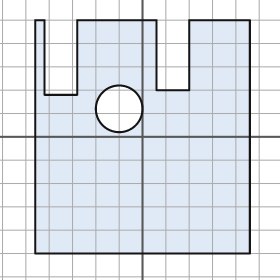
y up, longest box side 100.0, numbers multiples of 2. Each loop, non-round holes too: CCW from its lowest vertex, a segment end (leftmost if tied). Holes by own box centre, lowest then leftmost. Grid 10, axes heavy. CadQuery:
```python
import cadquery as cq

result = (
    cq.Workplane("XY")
    .moveTo(-46.0, -50.0)
    .lineTo(46.0, -50.0)
    .lineTo(46.0, 50.0)
    .lineTo(20.0, 50.0)
    .lineTo(20.0, 20.0)
    .lineTo(6.0, 20.0)
    .lineTo(6.0, 50.0)
    .lineTo(-28.0, 50.0)
    .lineTo(-28.0, 18.0)
    .lineTo(-42.0, 18.0)
    .lineTo(-42.0, 50.0)
    .lineTo(-46.0, 50.0)
    .close()
    .moveTo(-10.0, 12.0)
    .circle(10.0)
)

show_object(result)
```